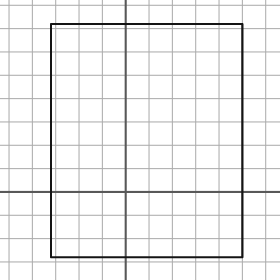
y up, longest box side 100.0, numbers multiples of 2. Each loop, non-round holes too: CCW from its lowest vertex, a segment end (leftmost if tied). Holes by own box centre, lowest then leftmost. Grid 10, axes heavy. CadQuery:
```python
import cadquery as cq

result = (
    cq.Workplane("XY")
    .moveTo(-32.0, -28.0)
    .lineTo(50.0, -28.0)
    .lineTo(50.0, 72.0)
    .lineTo(-32.0, 72.0)
    .close()
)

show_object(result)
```